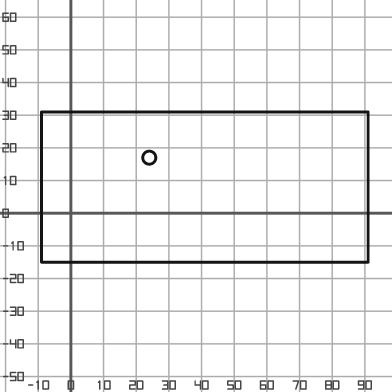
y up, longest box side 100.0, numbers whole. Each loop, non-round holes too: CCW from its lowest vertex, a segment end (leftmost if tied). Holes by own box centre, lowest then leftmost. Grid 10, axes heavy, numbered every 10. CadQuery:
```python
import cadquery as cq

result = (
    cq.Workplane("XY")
    .moveTo(-9.0, -15.0)
    .lineTo(91.0, -15.0)
    .lineTo(91.0, 31.0)
    .lineTo(-9.0, 31.0)
    .close()
    .moveTo(24.0, 17.0)
    .circle(2.0)
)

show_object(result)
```